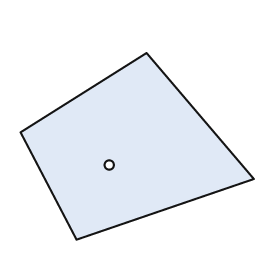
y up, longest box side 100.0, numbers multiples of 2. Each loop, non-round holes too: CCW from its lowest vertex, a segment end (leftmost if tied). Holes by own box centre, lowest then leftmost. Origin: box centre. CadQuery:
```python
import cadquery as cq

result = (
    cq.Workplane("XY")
    .moveTo(-26.0, -40.0)
    .lineTo(50.0, -14.0)
    .lineTo(4.0, 40.0)
    .lineTo(-50.0, 6.0)
    .close()
    .moveTo(-12.0, -8.0)
    .circle(2.0)
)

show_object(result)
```